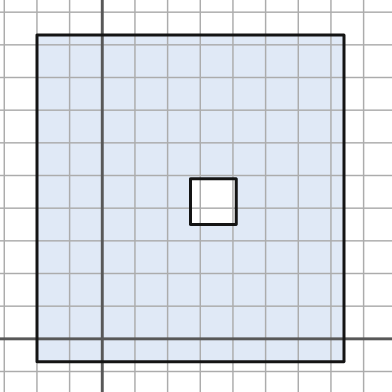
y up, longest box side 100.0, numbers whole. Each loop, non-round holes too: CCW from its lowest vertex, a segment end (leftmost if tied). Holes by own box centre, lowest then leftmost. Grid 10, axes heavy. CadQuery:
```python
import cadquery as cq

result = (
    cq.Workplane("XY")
    .moveTo(-20.0, -7.0)
    .lineTo(74.0, -7.0)
    .lineTo(74.0, 93.0)
    .lineTo(-20.0, 93.0)
    .close()
    .moveTo(27.0, 35.0)
    .lineTo(41.0, 35.0)
    .lineTo(41.0, 49.0)
    .lineTo(27.0, 49.0)
    .close()
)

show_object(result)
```